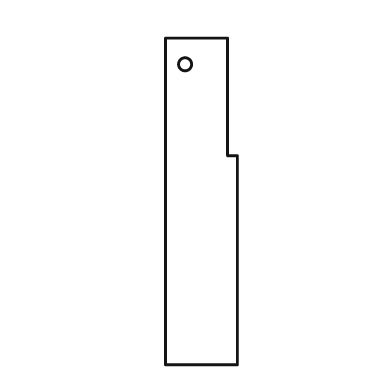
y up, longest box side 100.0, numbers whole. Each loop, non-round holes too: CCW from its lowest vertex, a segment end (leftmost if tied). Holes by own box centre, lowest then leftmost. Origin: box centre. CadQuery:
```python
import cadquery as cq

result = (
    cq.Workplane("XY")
    .moveTo(-11.0, -50.0)
    .lineTo(11.0, -50.0)
    .lineTo(11.0, 14.0)
    .lineTo(8.0, 14.0)
    .lineTo(8.0, 50.0)
    .lineTo(-11.0, 50.0)
    .close()
    .moveTo(-5.0, 42.0)
    .circle(2.0)
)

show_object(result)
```